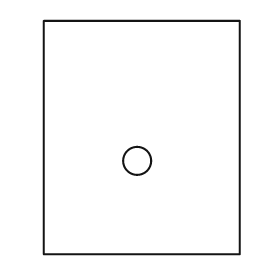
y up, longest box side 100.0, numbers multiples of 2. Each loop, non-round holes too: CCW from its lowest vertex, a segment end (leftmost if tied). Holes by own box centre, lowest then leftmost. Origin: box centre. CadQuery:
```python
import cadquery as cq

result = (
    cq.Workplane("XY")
    .moveTo(-42.0, -50.0)
    .lineTo(42.0, -50.0)
    .lineTo(42.0, 50.0)
    .lineTo(-42.0, 50.0)
    .close()
    .moveTo(-2.0, -10.0)
    .circle(6.0)
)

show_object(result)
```